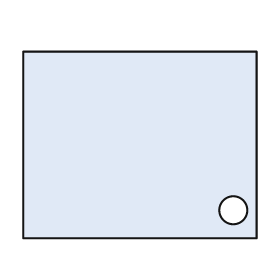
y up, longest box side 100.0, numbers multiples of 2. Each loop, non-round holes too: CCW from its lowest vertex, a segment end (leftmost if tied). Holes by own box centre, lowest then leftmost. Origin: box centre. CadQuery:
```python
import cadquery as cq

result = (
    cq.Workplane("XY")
    .moveTo(-50.0, -40.0)
    .lineTo(50.0, -40.0)
    .lineTo(50.0, 40.0)
    .lineTo(-50.0, 40.0)
    .close()
    .moveTo(40.0, -28.0)
    .circle(6.0)
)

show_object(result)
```